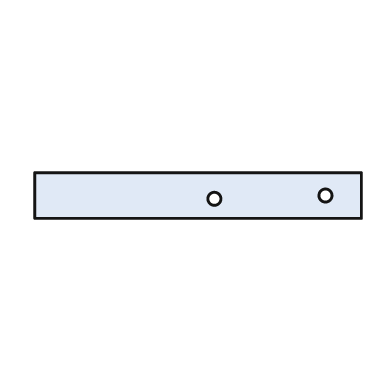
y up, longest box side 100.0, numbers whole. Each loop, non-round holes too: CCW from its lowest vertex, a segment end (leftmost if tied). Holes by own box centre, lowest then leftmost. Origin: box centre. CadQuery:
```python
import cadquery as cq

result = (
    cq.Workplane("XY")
    .moveTo(-50.0, -7.0)
    .lineTo(50.0, -7.0)
    .lineTo(50.0, 7.0)
    .lineTo(-50.0, 7.0)
    .close()
    .moveTo(5.0, -1.0)
    .circle(2.0)
    .moveTo(39.0, 0.0)
    .circle(2.0)
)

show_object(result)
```